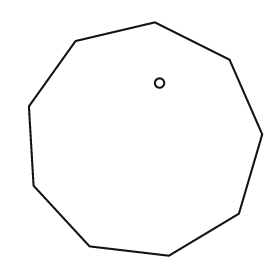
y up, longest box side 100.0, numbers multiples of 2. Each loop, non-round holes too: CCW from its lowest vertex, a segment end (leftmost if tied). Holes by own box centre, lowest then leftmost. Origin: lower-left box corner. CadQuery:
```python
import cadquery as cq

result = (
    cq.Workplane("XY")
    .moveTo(60.0, 0.0)
    .lineTo(90.0, 18.0)
    .lineTo(100.0, 52.0)
    .lineTo(86.0, 84.0)
    .lineTo(54.0, 100.0)
    .lineTo(20.0, 92.0)
    .lineTo(0.0, 64.0)
    .lineTo(2.0, 30.0)
    .lineTo(26.0, 4.0)
    .close()
    .moveTo(56.0, 74.0)
    .circle(2.0)
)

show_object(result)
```